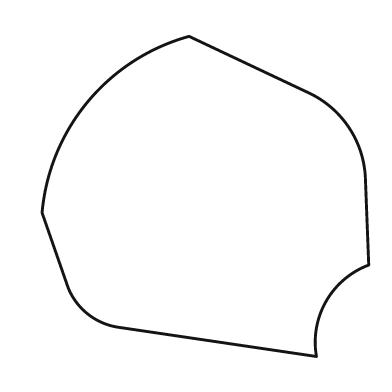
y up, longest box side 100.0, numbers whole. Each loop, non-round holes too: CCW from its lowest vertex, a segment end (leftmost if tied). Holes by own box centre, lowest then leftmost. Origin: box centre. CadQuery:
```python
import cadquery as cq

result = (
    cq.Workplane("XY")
    .moveTo(34.0, -49.0)
    .threePointArc((37.0, -32.0), (50.0, -21.0))
    .lineTo(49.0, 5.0)
    .threePointArc((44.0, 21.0), (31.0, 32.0))
    .lineTo(-5.0, 49.0)
    .threePointArc((-36.0, 29.0), (-50.0, -5.0))
    .lineTo(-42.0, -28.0)
    .threePointArc((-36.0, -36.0), (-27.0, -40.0))
    .close()
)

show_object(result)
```